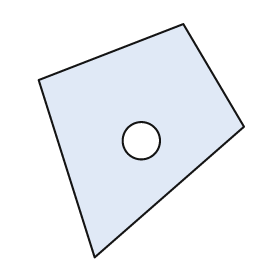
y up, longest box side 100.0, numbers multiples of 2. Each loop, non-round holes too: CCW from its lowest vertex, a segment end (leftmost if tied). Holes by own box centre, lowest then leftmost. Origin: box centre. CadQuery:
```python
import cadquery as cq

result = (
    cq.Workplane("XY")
    .moveTo(-20.0, -50.0)
    .lineTo(44.0, 6.0)
    .lineTo(18.0, 50.0)
    .lineTo(-44.0, 26.0)
    .close()
    .moveTo(0.0, 0.0)
    .circle(8.0)
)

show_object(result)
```